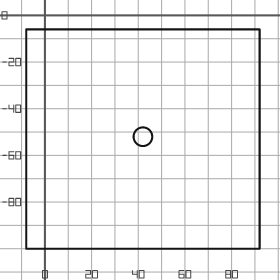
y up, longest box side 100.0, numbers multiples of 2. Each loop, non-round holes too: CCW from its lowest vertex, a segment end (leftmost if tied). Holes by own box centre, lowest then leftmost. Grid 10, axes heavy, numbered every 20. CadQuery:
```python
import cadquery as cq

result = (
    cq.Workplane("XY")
    .moveTo(-8.0, -100.0)
    .lineTo(92.0, -100.0)
    .lineTo(92.0, -6.0)
    .lineTo(-8.0, -6.0)
    .close()
    .moveTo(42.0, -52.0)
    .circle(4.0)
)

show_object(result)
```